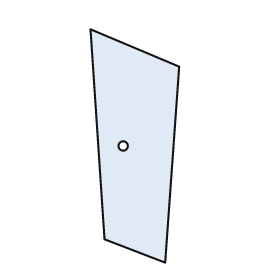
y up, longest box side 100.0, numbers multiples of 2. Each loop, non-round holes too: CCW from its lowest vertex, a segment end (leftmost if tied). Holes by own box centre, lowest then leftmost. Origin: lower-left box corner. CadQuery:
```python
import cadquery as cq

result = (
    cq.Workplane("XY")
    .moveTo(32.0, 0.0)
    .lineTo(38.0, 84.0)
    .lineTo(0.0, 100.0)
    .lineTo(6.0, 10.0)
    .close()
    .moveTo(14.0, 50.0)
    .circle(2.0)
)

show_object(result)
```